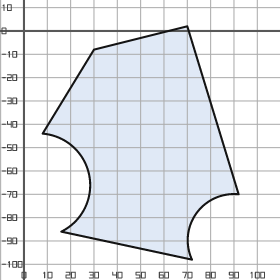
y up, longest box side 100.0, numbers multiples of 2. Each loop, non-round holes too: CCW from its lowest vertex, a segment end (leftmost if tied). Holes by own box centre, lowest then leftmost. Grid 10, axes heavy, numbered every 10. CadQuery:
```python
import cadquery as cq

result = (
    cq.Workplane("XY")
    .moveTo(72.0, -98.0)
    .threePointArc((74.0, -78.0), (92.0, -70.0))
    .lineTo(70.0, 2.0)
    .lineTo(30.0, -8.0)
    .lineTo(8.0, -44.0)
    .threePointArc((28.0, -62.0), (16.0, -86.0))
    .close()
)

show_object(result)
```